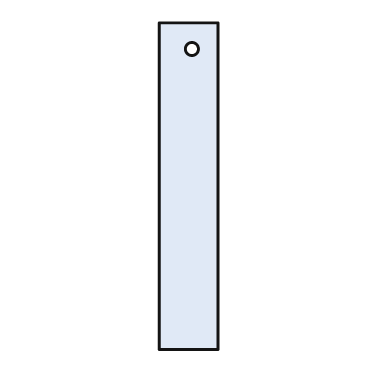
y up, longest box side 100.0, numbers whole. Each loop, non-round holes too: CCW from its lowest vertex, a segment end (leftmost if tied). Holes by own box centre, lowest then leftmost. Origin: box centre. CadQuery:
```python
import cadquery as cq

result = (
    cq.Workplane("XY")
    .moveTo(-9.0, -50.0)
    .lineTo(9.0, -50.0)
    .lineTo(9.0, 50.0)
    .lineTo(-9.0, 50.0)
    .close()
    .moveTo(1.0, 42.0)
    .circle(2.0)
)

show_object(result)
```